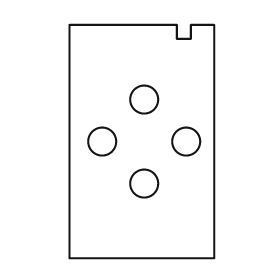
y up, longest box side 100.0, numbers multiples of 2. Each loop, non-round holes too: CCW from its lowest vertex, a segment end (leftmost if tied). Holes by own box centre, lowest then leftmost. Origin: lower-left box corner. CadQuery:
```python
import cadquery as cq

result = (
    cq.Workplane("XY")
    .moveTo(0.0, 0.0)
    .lineTo(62.0, 0.0)
    .lineTo(62.0, 100.0)
    .lineTo(52.0, 100.0)
    .lineTo(52.0, 94.0)
    .lineTo(46.0, 94.0)
    .lineTo(46.0, 100.0)
    .lineTo(0.0, 100.0)
    .close()
    .moveTo(32.0, 32.0)
    .circle(6.0)
    .moveTo(14.0, 50.0)
    .circle(6.0)
    .moveTo(50.0, 50.0)
    .circle(6.0)
    .moveTo(32.0, 68.0)
    .circle(6.0)
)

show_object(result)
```